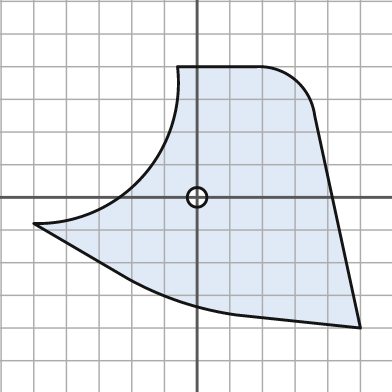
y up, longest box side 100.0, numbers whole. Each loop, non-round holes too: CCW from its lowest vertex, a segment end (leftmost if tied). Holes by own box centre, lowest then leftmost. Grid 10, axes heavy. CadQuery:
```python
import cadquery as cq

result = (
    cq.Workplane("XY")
    .moveTo(50.0, -40.0)
    .lineTo(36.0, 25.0)
    .threePointArc((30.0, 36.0), (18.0, 40.0))
    .lineTo(-6.0, 40.0)
    .threePointArc((-17.0, 6.0), (-50.0, -8.0))
    .lineTo(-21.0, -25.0)
    .threePointArc((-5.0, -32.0), (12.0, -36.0))
    .close()
    .moveTo(0.0, 0.0)
    .circle(3.0)
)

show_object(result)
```